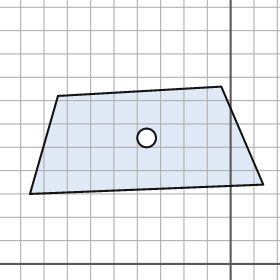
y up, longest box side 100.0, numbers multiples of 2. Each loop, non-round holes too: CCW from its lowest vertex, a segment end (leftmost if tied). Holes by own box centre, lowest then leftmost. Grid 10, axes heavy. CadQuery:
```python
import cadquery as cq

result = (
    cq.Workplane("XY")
    .moveTo(-86.0, 30.0)
    .lineTo(14.0, 34.0)
    .lineTo(-4.0, 76.0)
    .lineTo(-74.0, 72.0)
    .close()
    .moveTo(-36.0, 54.0)
    .circle(4.0)
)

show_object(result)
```